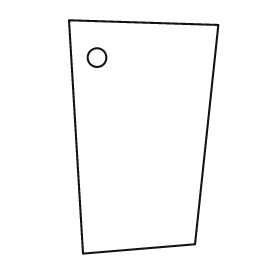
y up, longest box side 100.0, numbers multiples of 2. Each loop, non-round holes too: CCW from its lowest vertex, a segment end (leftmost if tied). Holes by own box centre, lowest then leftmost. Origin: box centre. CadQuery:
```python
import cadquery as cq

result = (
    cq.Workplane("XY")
    .moveTo(-26.0, -50.0)
    .lineTo(22.0, -46.0)
    .lineTo(32.0, 48.0)
    .lineTo(-32.0, 50.0)
    .close()
    .moveTo(-20.0, 34.0)
    .circle(4.0)
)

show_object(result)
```